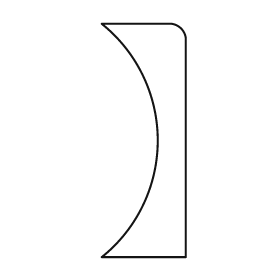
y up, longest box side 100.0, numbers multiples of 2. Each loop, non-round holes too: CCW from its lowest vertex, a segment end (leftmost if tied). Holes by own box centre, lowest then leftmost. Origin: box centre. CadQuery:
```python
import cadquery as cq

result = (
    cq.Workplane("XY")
    .moveTo(-18.0, -50.0)
    .lineTo(18.0, -50.0)
    .lineTo(18.0, 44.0)
    .threePointArc((16.0, 48.0), (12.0, 50.0))
    .lineTo(-18.0, 50.0)
    .threePointArc((6.0, 0.0), (-18.0, -50.0))
    .close()
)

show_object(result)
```